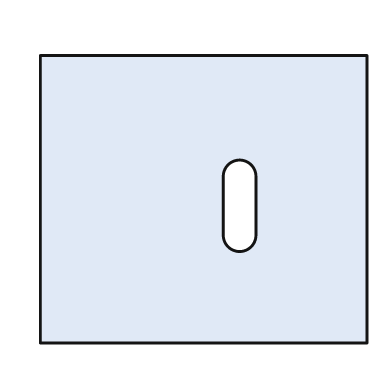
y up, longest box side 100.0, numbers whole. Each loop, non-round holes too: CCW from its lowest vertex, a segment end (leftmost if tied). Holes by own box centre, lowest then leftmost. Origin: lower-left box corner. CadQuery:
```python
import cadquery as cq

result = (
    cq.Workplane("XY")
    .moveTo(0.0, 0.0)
    .lineTo(100.0, 0.0)
    .lineTo(100.0, 88.0)
    .lineTo(0.0, 88.0)
    .close()
    .moveTo(56.0, 33.0)
    .threePointArc((61.0, 28.0), (66.0, 33.0))
    .lineTo(66.0, 51.0)
    .threePointArc((61.0, 56.0), (56.0, 51.0))
    .close()
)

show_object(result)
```